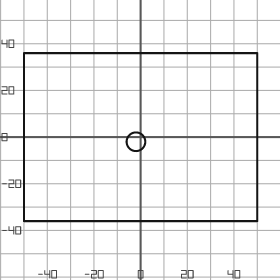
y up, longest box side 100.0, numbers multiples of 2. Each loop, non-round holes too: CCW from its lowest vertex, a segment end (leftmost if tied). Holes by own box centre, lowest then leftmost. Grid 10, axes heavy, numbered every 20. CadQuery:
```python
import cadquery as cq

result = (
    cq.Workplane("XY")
    .moveTo(-50.0, -36.0)
    .lineTo(50.0, -36.0)
    .lineTo(50.0, 36.0)
    .lineTo(-50.0, 36.0)
    .close()
    .moveTo(-2.0, -2.0)
    .circle(4.0)
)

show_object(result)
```